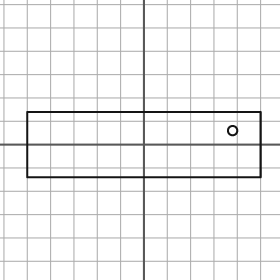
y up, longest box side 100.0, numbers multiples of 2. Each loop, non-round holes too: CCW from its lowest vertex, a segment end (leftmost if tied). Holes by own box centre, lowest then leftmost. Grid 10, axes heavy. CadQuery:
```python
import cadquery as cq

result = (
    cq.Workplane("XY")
    .moveTo(-50.0, -14.0)
    .lineTo(50.0, -14.0)
    .lineTo(50.0, 14.0)
    .lineTo(-50.0, 14.0)
    .close()
    .moveTo(38.0, 6.0)
    .circle(2.0)
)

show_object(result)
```